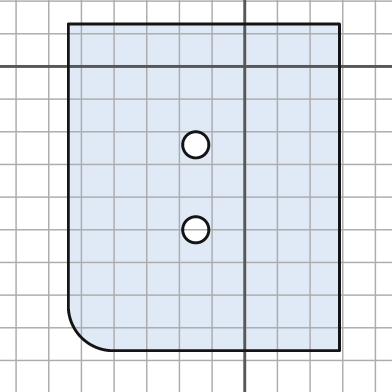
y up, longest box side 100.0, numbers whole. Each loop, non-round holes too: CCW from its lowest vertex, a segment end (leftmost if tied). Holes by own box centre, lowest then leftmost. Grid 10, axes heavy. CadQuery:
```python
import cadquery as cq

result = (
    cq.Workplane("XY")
    .moveTo(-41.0, -87.0)
    .lineTo(29.0, -87.0)
    .lineTo(29.0, 13.0)
    .lineTo(-54.0, 13.0)
    .lineTo(-54.0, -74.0)
    .threePointArc((-50.0, -83.0), (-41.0, -87.0))
    .close()
    .moveTo(-15.0, -50.0)
    .circle(4.0)
    .moveTo(-15.0, -24.0)
    .circle(4.0)
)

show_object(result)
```